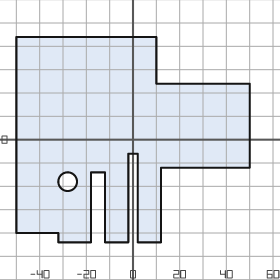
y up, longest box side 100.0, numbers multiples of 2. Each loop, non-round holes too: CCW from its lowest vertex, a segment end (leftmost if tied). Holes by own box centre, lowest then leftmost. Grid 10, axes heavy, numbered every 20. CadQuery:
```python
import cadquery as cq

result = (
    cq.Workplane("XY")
    .moveTo(-32.0, -44.0)
    .lineTo(-18.0, -44.0)
    .lineTo(-18.0, -14.0)
    .lineTo(-12.0, -14.0)
    .lineTo(-12.0, -44.0)
    .lineTo(-2.0, -44.0)
    .lineTo(-2.0, -6.0)
    .lineTo(2.0, -6.0)
    .lineTo(2.0, -44.0)
    .lineTo(12.0, -44.0)
    .lineTo(12.0, -12.0)
    .lineTo(50.0, -12.0)
    .lineTo(50.0, 24.0)
    .lineTo(10.0, 24.0)
    .lineTo(10.0, 44.0)
    .lineTo(-50.0, 44.0)
    .lineTo(-50.0, -40.0)
    .lineTo(-32.0, -40.0)
    .close()
    .moveTo(-28.0, -18.0)
    .circle(4.0)
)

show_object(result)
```